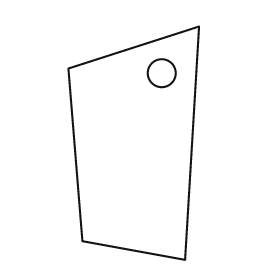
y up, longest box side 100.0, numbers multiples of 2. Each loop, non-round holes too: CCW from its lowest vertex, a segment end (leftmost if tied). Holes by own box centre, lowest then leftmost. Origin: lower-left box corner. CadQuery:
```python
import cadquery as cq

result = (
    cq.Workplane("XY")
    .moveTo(50.0, 0.0)
    .lineTo(56.0, 100.0)
    .lineTo(0.0, 82.0)
    .lineTo(6.0, 8.0)
    .close()
    .moveTo(40.0, 80.0)
    .circle(6.0)
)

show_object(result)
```